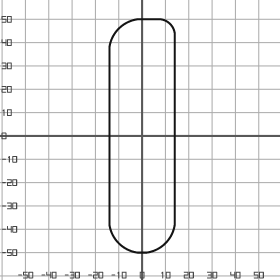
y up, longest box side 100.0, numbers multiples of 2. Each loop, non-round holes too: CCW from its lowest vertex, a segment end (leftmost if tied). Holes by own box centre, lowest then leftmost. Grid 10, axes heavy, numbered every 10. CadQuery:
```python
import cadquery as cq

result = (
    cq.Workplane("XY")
    .moveTo(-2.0, -50.0)
    .lineTo(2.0, -50.0)
    .threePointArc((10.0, -46.0), (14.0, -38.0))
    .lineTo(14.0, 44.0)
    .threePointArc((12.0, 48.0), (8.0, 50.0))
    .lineTo(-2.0, 50.0)
    .threePointArc((-10.0, 46.0), (-14.0, 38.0))
    .lineTo(-14.0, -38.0)
    .threePointArc((-10.0, -46.0), (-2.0, -50.0))
    .close()
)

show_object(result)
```